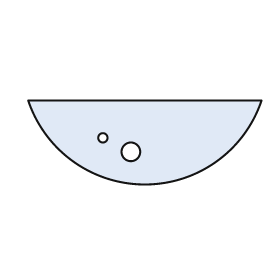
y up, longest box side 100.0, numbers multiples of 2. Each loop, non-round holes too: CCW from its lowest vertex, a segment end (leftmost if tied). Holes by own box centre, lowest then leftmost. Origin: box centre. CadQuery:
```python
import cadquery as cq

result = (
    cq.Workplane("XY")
    .moveTo(-50.0, 18.0)
    .threePointArc((0.0, -18.0), (50.0, 18.0))
    .close()
    .moveTo(-6.0, -4.0)
    .circle(4.0)
    .moveTo(-18.0, 2.0)
    .circle(2.0)
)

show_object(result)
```